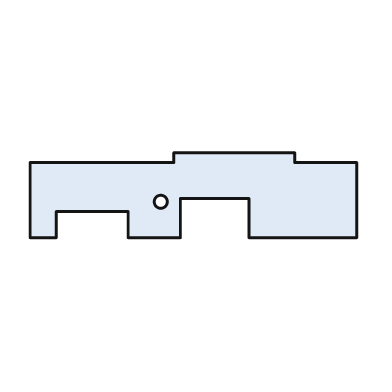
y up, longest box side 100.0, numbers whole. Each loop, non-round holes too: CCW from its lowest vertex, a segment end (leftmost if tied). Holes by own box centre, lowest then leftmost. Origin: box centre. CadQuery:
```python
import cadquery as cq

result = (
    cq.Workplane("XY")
    .moveTo(-50.0, -13.0)
    .lineTo(-42.0, -13.0)
    .lineTo(-42.0, -5.0)
    .lineTo(-20.0, -5.0)
    .lineTo(-20.0, -13.0)
    .lineTo(-4.0, -13.0)
    .lineTo(-4.0, -1.0)
    .lineTo(17.0, -1.0)
    .lineTo(17.0, -13.0)
    .lineTo(50.0, -13.0)
    .lineTo(50.0, 10.0)
    .lineTo(31.0, 10.0)
    .lineTo(31.0, 13.0)
    .lineTo(-6.0, 13.0)
    .lineTo(-6.0, 10.0)
    .lineTo(-50.0, 10.0)
    .close()
    .moveTo(-10.0, -2.0)
    .circle(2.0)
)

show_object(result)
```